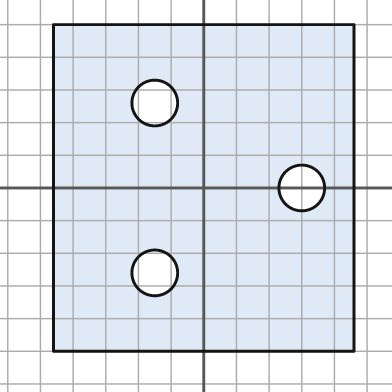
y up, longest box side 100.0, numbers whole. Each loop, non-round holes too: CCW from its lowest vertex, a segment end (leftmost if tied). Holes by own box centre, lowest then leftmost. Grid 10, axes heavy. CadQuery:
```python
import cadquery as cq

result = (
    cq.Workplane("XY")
    .moveTo(-46.0, -50.0)
    .lineTo(46.0, -50.0)
    .lineTo(46.0, 50.0)
    .lineTo(-46.0, 50.0)
    .close()
    .moveTo(-15.0, -26.0)
    .circle(7.0)
    .moveTo(30.0, 0.0)
    .circle(7.0)
    .moveTo(-15.0, 26.0)
    .circle(7.0)
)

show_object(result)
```